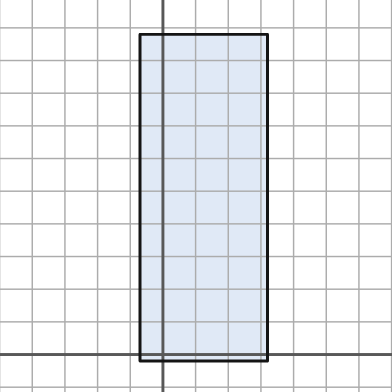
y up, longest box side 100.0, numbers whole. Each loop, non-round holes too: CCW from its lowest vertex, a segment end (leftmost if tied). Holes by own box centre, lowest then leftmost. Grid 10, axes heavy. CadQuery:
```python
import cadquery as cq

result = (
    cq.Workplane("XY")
    .moveTo(-7.0, -2.0)
    .lineTo(32.0, -2.0)
    .lineTo(32.0, 98.0)
    .lineTo(-7.0, 98.0)
    .close()
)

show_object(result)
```